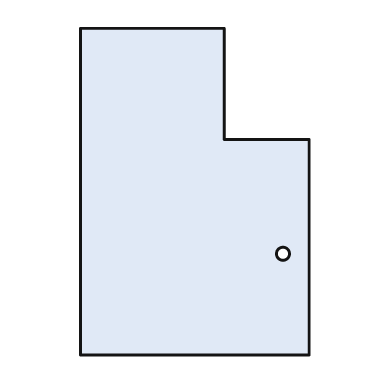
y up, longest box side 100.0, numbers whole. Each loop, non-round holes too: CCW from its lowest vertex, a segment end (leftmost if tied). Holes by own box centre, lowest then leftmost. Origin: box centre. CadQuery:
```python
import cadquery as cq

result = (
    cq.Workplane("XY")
    .moveTo(-35.0, -50.0)
    .lineTo(35.0, -50.0)
    .lineTo(35.0, 16.0)
    .lineTo(9.0, 16.0)
    .lineTo(9.0, 50.0)
    .lineTo(-35.0, 50.0)
    .close()
    .moveTo(27.0, -19.0)
    .circle(2.0)
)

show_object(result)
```